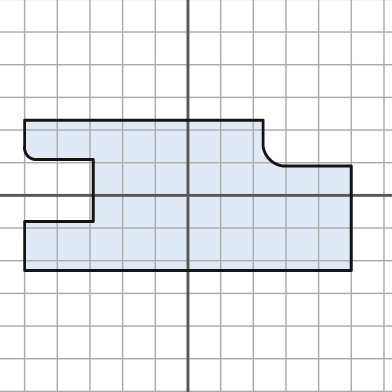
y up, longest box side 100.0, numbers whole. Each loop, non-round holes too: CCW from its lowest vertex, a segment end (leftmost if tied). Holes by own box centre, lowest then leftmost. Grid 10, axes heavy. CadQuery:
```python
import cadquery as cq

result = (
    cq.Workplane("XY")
    .moveTo(-50.0, -23.0)
    .lineTo(50.0, -23.0)
    .lineTo(50.0, 9.0)
    .lineTo(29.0, 9.0)
    .threePointArc((25.0, 11.0), (23.0, 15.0))
    .lineTo(23.0, 23.0)
    .lineTo(-50.0, 23.0)
    .lineTo(-50.0, 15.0)
    .threePointArc((-49.0, 12.0), (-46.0, 11.0))
    .lineTo(-29.0, 11.0)
    .lineTo(-29.0, -8.0)
    .lineTo(-50.0, -8.0)
    .close()
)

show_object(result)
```